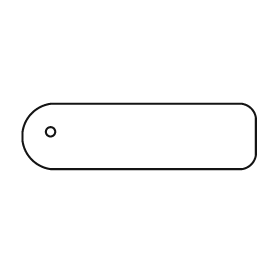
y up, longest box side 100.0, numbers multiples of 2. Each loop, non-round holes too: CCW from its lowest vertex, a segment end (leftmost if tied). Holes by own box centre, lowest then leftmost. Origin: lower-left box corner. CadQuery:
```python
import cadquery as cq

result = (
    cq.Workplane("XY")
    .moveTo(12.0, 0.0)
    .lineTo(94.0, 0.0)
    .threePointArc((98.0, 2.0), (100.0, 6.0))
    .lineTo(100.0, 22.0)
    .threePointArc((98.0, 26.0), (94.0, 28.0))
    .lineTo(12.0, 28.0)
    .threePointArc((4.0, 24.0), (0.0, 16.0))
    .lineTo(0.0, 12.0)
    .threePointArc((4.0, 4.0), (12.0, 0.0))
    .close()
    .moveTo(12.0, 16.0)
    .circle(2.0)
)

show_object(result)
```